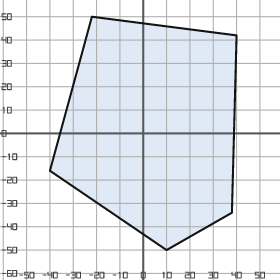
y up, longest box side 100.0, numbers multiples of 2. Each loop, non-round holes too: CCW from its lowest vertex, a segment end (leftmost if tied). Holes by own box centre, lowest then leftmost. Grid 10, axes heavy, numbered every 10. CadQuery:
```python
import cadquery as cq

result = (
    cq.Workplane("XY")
    .moveTo(10.0, -50.0)
    .lineTo(38.0, -34.0)
    .lineTo(40.0, 42.0)
    .lineTo(-22.0, 50.0)
    .lineTo(-40.0, -16.0)
    .close()
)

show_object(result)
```